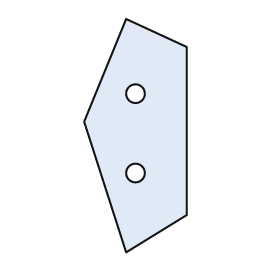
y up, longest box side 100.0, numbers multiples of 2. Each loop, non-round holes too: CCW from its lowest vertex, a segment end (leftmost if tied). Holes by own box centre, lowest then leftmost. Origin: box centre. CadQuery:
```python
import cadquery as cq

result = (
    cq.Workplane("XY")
    .moveTo(-4.0, -50.0)
    .lineTo(22.0, -34.0)
    .lineTo(22.0, 38.0)
    .lineTo(-4.0, 50.0)
    .lineTo(-22.0, 6.0)
    .close()
    .moveTo(0.0, -16.0)
    .circle(4.0)
    .moveTo(0.0, 18.0)
    .circle(4.0)
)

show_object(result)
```